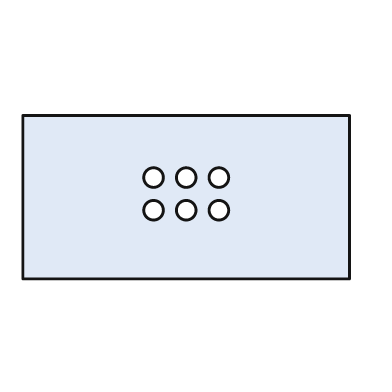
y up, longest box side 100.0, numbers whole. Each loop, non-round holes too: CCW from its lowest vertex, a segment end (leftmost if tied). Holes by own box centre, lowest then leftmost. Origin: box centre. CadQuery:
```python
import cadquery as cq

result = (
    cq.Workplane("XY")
    .moveTo(-50.0, -25.0)
    .lineTo(50.0, -25.0)
    .lineTo(50.0, 25.0)
    .lineTo(-50.0, 25.0)
    .close()
    .moveTo(-10.0, -4.0)
    .circle(3.0)
    .moveTo(0.0, -4.0)
    .circle(3.0)
    .moveTo(10.0, -4.0)
    .circle(3.0)
    .moveTo(-10.0, 6.0)
    .circle(3.0)
    .moveTo(0.0, 6.0)
    .circle(3.0)
    .moveTo(10.0, 6.0)
    .circle(3.0)
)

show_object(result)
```